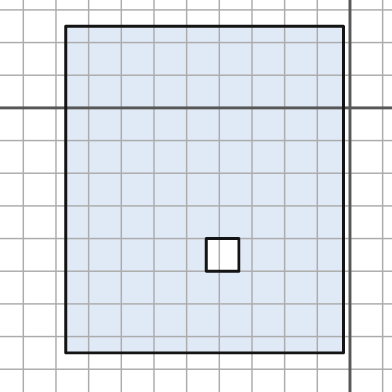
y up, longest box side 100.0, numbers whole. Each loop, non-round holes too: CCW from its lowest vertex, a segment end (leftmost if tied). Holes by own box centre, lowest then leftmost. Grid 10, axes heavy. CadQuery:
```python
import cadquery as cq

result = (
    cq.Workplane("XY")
    .moveTo(-87.0, -75.0)
    .lineTo(-2.0, -75.0)
    .lineTo(-2.0, 25.0)
    .lineTo(-87.0, 25.0)
    .close()
    .moveTo(-44.0, -50.0)
    .lineTo(-34.0, -50.0)
    .lineTo(-34.0, -40.0)
    .lineTo(-44.0, -40.0)
    .close()
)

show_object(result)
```